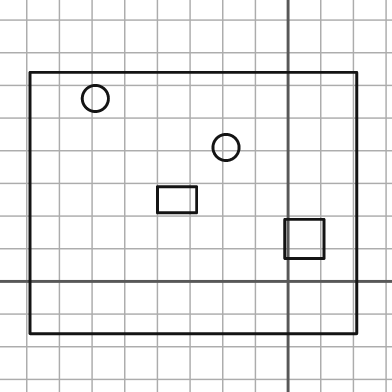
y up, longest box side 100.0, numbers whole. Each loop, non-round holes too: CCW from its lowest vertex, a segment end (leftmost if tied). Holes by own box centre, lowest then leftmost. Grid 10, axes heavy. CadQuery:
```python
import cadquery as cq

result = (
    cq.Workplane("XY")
    .moveTo(-79.0, -16.0)
    .lineTo(21.0, -16.0)
    .lineTo(21.0, 64.0)
    .lineTo(-79.0, 64.0)
    .close()
    .moveTo(-1.0, 7.0)
    .lineTo(11.0, 7.0)
    .lineTo(11.0, 19.0)
    .lineTo(-1.0, 19.0)
    .close()
    .moveTo(-40.0, 21.0)
    .lineTo(-28.0, 21.0)
    .lineTo(-28.0, 29.0)
    .lineTo(-40.0, 29.0)
    .close()
    .moveTo(-19.0, 41.0)
    .circle(4.0)
    .moveTo(-59.0, 56.0)
    .circle(4.0)
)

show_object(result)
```